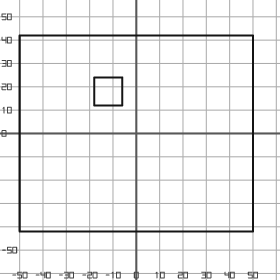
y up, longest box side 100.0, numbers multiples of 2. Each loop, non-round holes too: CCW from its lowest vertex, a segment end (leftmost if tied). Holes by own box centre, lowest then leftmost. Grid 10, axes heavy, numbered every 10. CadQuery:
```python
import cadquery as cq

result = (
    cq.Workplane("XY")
    .moveTo(-50.0, -42.0)
    .lineTo(50.0, -42.0)
    .lineTo(50.0, 42.0)
    .lineTo(-50.0, 42.0)
    .close()
    .moveTo(-18.0, 12.0)
    .lineTo(-6.0, 12.0)
    .lineTo(-6.0, 24.0)
    .lineTo(-18.0, 24.0)
    .close()
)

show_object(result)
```